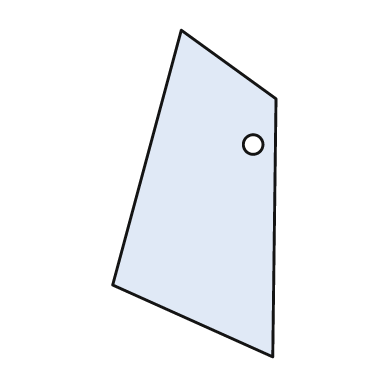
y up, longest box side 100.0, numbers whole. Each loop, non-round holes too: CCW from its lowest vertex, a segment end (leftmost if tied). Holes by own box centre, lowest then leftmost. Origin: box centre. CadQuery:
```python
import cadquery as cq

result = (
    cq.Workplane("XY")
    .moveTo(24.0, -50.0)
    .lineTo(25.0, 29.0)
    .lineTo(-4.0, 50.0)
    .lineTo(-25.0, -28.0)
    .close()
    .moveTo(18.0, 15.0)
    .circle(3.0)
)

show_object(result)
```